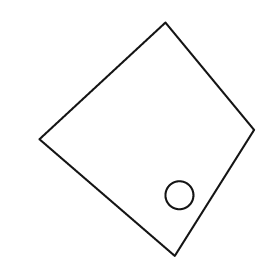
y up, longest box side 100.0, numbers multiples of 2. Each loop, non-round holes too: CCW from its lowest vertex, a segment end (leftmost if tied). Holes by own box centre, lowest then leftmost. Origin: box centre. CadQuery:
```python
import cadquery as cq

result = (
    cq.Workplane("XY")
    .moveTo(12.0, -50.0)
    .lineTo(46.0, 4.0)
    .lineTo(8.0, 50.0)
    .lineTo(-46.0, 0.0)
    .close()
    .moveTo(14.0, -24.0)
    .circle(6.0)
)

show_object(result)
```